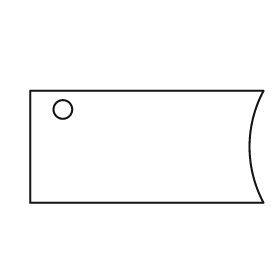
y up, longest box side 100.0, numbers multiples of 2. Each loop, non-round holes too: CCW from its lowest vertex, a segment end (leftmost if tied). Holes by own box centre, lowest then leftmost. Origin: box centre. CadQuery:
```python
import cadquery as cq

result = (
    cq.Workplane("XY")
    .moveTo(-50.0, -24.0)
    .lineTo(50.0, -24.0)
    .threePointArc((44.0, 0.0), (50.0, 24.0))
    .lineTo(-50.0, 24.0)
    .close()
    .moveTo(-36.0, 16.0)
    .circle(4.0)
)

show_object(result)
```